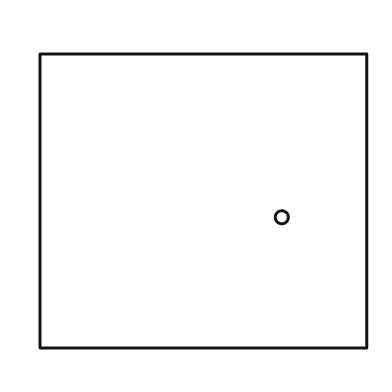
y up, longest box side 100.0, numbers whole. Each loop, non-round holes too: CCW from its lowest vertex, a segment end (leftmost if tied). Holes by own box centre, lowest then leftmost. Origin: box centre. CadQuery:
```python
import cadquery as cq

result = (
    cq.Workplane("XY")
    .moveTo(-50.0, -45.0)
    .lineTo(50.0, -45.0)
    .lineTo(50.0, 45.0)
    .lineTo(-50.0, 45.0)
    .close()
    .moveTo(24.0, -5.0)
    .circle(2.0)
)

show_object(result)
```